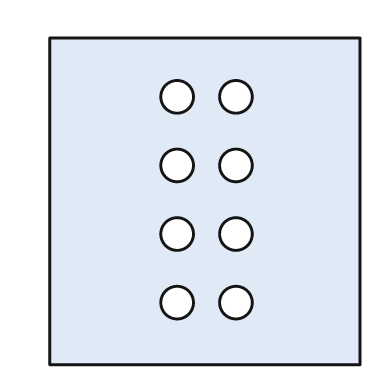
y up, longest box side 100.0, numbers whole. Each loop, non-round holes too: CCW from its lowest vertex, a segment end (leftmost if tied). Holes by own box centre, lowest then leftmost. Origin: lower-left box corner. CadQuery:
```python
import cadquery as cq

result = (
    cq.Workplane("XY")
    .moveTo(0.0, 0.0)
    .lineTo(95.0, 0.0)
    .lineTo(95.0, 100.0)
    .lineTo(0.0, 100.0)
    .close()
    .moveTo(39.0, 19.0)
    .circle(5.0)
    .moveTo(57.0, 19.0)
    .circle(5.0)
    .moveTo(39.0, 40.0)
    .circle(5.0)
    .moveTo(57.0, 40.0)
    .circle(5.0)
    .moveTo(39.0, 61.0)
    .circle(5.0)
    .moveTo(57.0, 61.0)
    .circle(5.0)
    .moveTo(39.0, 82.0)
    .circle(5.0)
    .moveTo(57.0, 82.0)
    .circle(5.0)
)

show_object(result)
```